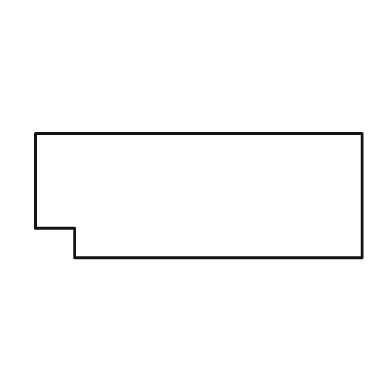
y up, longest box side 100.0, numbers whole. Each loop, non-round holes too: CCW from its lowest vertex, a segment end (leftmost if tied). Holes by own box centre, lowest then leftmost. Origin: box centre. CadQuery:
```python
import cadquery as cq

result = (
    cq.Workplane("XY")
    .moveTo(-38.0, -19.0)
    .lineTo(50.0, -19.0)
    .lineTo(50.0, 19.0)
    .lineTo(-50.0, 19.0)
    .lineTo(-50.0, -10.0)
    .lineTo(-38.0, -10.0)
    .close()
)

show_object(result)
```